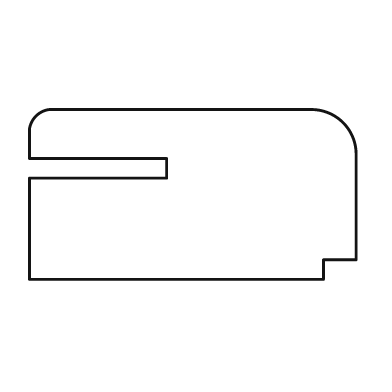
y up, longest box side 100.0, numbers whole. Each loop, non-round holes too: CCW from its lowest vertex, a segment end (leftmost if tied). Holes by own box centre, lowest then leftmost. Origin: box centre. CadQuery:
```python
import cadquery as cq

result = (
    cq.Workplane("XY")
    .moveTo(-50.0, -26.0)
    .lineTo(40.0, -26.0)
    .lineTo(40.0, -20.0)
    .lineTo(50.0, -20.0)
    .lineTo(50.0, 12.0)
    .threePointArc((46.0, 22.0), (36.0, 26.0))
    .lineTo(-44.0, 26.0)
    .threePointArc((-48.0, 24.0), (-50.0, 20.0))
    .lineTo(-50.0, 11.0)
    .lineTo(-8.0, 11.0)
    .lineTo(-8.0, 5.0)
    .lineTo(-50.0, 5.0)
    .close()
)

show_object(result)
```